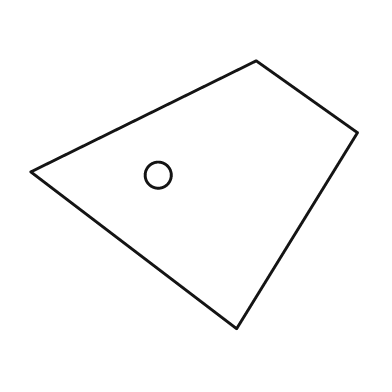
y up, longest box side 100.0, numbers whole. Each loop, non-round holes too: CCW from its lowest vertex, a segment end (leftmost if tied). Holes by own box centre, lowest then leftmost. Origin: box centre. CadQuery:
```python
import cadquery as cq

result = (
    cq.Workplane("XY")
    .moveTo(13.0, -41.0)
    .lineTo(50.0, 19.0)
    .lineTo(19.0, 41.0)
    .lineTo(-50.0, 7.0)
    .close()
    .moveTo(-11.0, 6.0)
    .circle(4.0)
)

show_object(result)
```